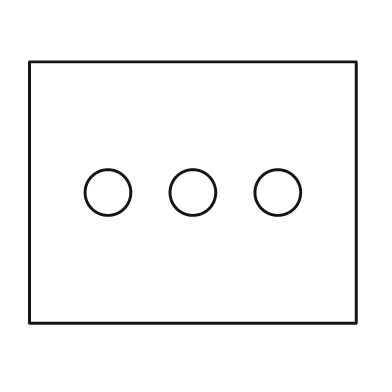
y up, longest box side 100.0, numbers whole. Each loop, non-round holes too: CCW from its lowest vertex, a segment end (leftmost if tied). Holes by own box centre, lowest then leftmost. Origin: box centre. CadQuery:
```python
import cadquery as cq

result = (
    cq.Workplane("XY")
    .moveTo(-50.0, -40.0)
    .lineTo(50.0, -40.0)
    .lineTo(50.0, 40.0)
    .lineTo(-50.0, 40.0)
    .close()
    .moveTo(-26.0, 0.0)
    .circle(7.0)
    .moveTo(0.0, 0.0)
    .circle(7.0)
    .moveTo(26.0, 0.0)
    .circle(7.0)
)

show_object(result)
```